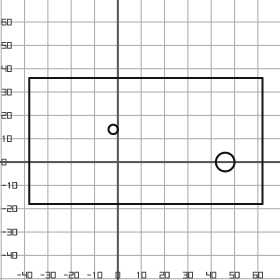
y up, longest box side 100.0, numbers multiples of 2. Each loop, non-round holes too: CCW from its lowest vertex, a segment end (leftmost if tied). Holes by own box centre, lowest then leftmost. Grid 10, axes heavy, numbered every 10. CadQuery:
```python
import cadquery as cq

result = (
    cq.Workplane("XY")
    .moveTo(-38.0, -18.0)
    .lineTo(62.0, -18.0)
    .lineTo(62.0, 36.0)
    .lineTo(-38.0, 36.0)
    .close()
    .moveTo(46.0, 0.0)
    .circle(4.0)
    .moveTo(-2.0, 14.0)
    .circle(2.0)
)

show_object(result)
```